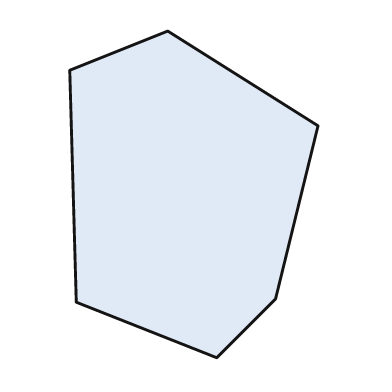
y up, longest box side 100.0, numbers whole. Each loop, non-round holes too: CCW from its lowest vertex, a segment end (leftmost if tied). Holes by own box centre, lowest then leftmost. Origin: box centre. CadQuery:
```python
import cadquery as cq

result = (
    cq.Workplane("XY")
    .moveTo(7.0, -50.0)
    .lineTo(25.0, -32.0)
    .lineTo(38.0, 21.0)
    .lineTo(-8.0, 50.0)
    .lineTo(-38.0, 38.0)
    .lineTo(-36.0, -33.0)
    .close()
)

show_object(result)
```